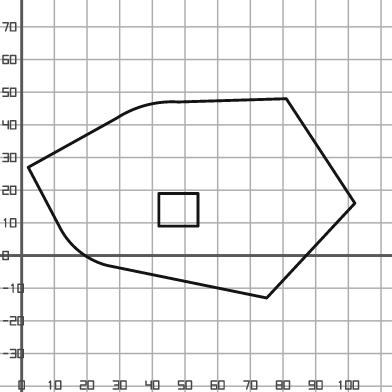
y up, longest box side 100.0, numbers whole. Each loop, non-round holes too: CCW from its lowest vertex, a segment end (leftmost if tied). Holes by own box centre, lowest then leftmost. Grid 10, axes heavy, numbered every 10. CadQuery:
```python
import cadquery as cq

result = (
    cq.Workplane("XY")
    .moveTo(75.0, -13.0)
    .lineTo(102.0, 16.0)
    .lineTo(81.0, 48.0)
    .lineTo(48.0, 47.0)
    .threePointArc((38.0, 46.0), (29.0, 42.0))
    .lineTo(2.0, 27.0)
    .lineTo(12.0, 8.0)
    .threePointArc((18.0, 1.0), (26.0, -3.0))
    .close()
    .moveTo(42.0, 9.0)
    .lineTo(54.0, 9.0)
    .lineTo(54.0, 19.0)
    .lineTo(42.0, 19.0)
    .close()
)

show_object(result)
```